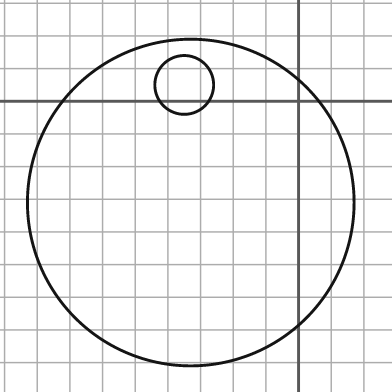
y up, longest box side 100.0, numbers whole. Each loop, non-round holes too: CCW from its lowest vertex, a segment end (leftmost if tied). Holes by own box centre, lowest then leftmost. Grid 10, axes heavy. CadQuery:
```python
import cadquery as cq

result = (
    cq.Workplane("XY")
    .moveTo(-33.0, -31.0)
    .circle(50.0)
    .moveTo(-35.0, 5.0)
    .circle(9.0)
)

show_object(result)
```